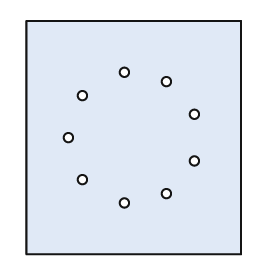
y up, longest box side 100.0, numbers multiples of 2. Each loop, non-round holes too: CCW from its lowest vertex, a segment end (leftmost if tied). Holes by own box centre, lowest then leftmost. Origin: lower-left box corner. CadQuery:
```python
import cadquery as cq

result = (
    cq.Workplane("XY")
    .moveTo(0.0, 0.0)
    .lineTo(92.0, 0.0)
    .lineTo(92.0, 100.0)
    .lineTo(0.0, 100.0)
    .close()
    .moveTo(42.0, 22.0)
    .circle(2.0)
    .moveTo(60.0, 26.0)
    .circle(2.0)
    .moveTo(24.0, 32.0)
    .circle(2.0)
    .moveTo(72.0, 40.0)
    .circle(2.0)
    .moveTo(18.0, 50.0)
    .circle(2.0)
    .moveTo(72.0, 60.0)
    .circle(2.0)
    .moveTo(24.0, 68.0)
    .circle(2.0)
    .moveTo(60.0, 74.0)
    .circle(2.0)
    .moveTo(42.0, 78.0)
    .circle(2.0)
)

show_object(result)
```